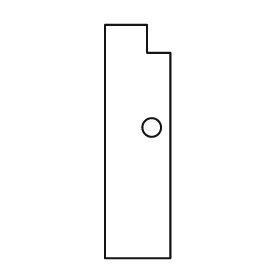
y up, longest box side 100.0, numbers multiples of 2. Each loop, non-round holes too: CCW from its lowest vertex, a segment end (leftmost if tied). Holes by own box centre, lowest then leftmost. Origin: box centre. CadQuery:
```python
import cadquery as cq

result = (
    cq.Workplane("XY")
    .moveTo(-14.0, -50.0)
    .lineTo(14.0, -50.0)
    .lineTo(14.0, 38.0)
    .lineTo(4.0, 38.0)
    .lineTo(4.0, 50.0)
    .lineTo(-14.0, 50.0)
    .close()
    .moveTo(6.0, 6.0)
    .circle(4.0)
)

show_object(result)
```